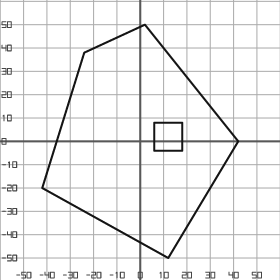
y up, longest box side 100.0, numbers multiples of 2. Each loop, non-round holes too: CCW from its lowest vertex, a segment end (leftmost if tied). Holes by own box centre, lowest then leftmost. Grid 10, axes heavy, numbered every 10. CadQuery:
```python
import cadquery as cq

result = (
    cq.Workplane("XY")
    .moveTo(12.0, -50.0)
    .lineTo(42.0, 0.0)
    .lineTo(2.0, 50.0)
    .lineTo(-24.0, 38.0)
    .lineTo(-42.0, -20.0)
    .close()
    .moveTo(6.0, -4.0)
    .lineTo(18.0, -4.0)
    .lineTo(18.0, 8.0)
    .lineTo(6.0, 8.0)
    .close()
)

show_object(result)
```